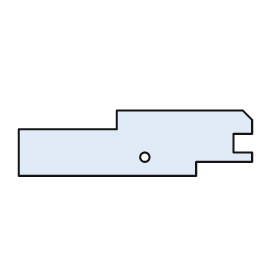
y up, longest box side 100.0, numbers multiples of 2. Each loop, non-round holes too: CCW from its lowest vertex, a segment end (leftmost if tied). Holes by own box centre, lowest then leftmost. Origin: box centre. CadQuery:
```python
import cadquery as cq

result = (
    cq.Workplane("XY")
    .moveTo(-50.0, -14.0)
    .lineTo(26.0, -14.0)
    .lineTo(26.0, -8.0)
    .lineTo(50.0, -8.0)
    .lineTo(50.0, -4.0)
    .lineTo(42.0, -4.0)
    .lineTo(42.0, 4.0)
    .lineTo(50.0, 4.0)
    .lineTo(50.0, 10.0)
    .lineTo(46.0, 14.0)
    .lineTo(-8.0, 14.0)
    .lineTo(-8.0, 6.0)
    .lineTo(-50.0, 6.0)
    .close()
    .moveTo(4.0, -6.0)
    .circle(2.0)
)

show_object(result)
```